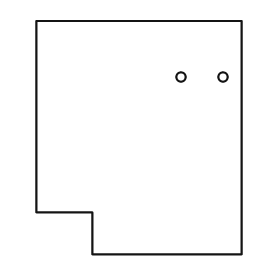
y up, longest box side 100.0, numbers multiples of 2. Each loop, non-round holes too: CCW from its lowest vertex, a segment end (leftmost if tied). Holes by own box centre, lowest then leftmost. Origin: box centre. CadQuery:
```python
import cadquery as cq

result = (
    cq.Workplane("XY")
    .moveTo(-20.0, -50.0)
    .lineTo(44.0, -50.0)
    .lineTo(44.0, 50.0)
    .lineTo(-44.0, 50.0)
    .lineTo(-44.0, -32.0)
    .lineTo(-20.0, -32.0)
    .close()
    .moveTo(18.0, 26.0)
    .circle(2.0)
    .moveTo(36.0, 26.0)
    .circle(2.0)
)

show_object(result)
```